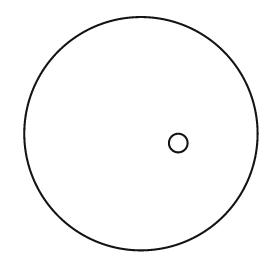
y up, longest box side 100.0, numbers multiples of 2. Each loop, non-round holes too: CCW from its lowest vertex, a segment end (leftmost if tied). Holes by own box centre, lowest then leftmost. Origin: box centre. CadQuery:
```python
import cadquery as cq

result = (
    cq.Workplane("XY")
    .moveTo(0.0, 0.0)
    .circle(50.0)
    .moveTo(16.0, -4.0)
    .circle(4.0)
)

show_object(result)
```